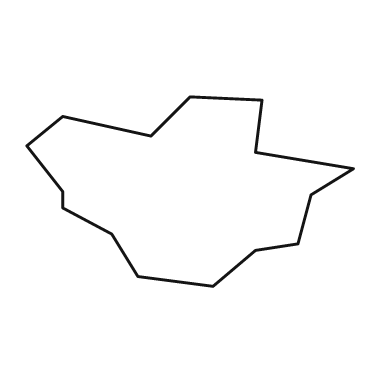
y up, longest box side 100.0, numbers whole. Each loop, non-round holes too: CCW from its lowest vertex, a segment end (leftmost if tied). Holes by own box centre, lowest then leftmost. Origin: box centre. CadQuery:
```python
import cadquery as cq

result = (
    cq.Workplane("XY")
    .moveTo(7.0, -29.0)
    .lineTo(20.0, -18.0)
    .lineTo(33.0, -16.0)
    .lineTo(37.0, -1.0)
    .lineTo(50.0, 7.0)
    .lineTo(20.0, 12.0)
    .lineTo(22.0, 28.0)
    .lineTo(0.0, 29.0)
    .lineTo(-12.0, 17.0)
    .lineTo(-39.0, 23.0)
    .lineTo(-50.0, 14.0)
    .lineTo(-39.0, 0.0)
    .lineTo(-39.0, -5.0)
    .lineTo(-24.0, -13.0)
    .lineTo(-16.0, -26.0)
    .close()
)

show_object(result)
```